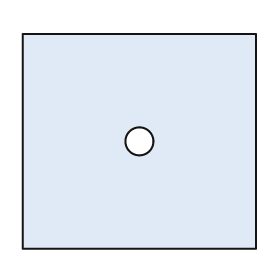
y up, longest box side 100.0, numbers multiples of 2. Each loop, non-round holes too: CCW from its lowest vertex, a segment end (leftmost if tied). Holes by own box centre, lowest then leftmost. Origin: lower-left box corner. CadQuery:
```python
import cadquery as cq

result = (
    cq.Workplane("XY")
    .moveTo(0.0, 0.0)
    .lineTo(100.0, 0.0)
    .lineTo(100.0, 92.0)
    .lineTo(0.0, 92.0)
    .close()
    .moveTo(50.0, 46.0)
    .circle(6.0)
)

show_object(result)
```